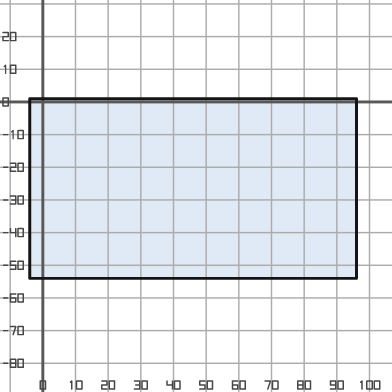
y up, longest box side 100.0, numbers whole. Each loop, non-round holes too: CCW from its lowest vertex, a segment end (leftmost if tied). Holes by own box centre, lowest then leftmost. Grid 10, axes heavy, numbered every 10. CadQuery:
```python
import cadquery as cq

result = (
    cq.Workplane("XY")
    .moveTo(-4.0, -54.0)
    .lineTo(96.0, -54.0)
    .lineTo(96.0, 1.0)
    .lineTo(-4.0, 1.0)
    .close()
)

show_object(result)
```